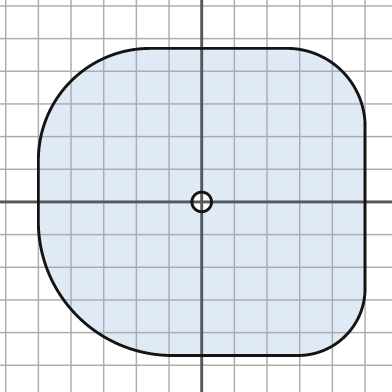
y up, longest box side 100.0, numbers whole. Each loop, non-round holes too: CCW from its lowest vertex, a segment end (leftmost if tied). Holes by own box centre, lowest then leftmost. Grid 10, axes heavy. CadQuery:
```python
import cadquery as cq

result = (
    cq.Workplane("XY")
    .moveTo(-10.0, -47.0)
    .lineTo(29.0, -47.0)
    .threePointArc((44.0, -41.0), (50.0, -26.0))
    .lineTo(50.0, 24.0)
    .threePointArc((43.0, 40.0), (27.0, 47.0))
    .lineTo(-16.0, 47.0)
    .threePointArc((-40.0, 37.0), (-50.0, 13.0))
    .lineTo(-50.0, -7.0)
    .threePointArc((-38.0, -35.0), (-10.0, -47.0))
    .close()
    .moveTo(0.0, 0.0)
    .circle(3.0)
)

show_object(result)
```